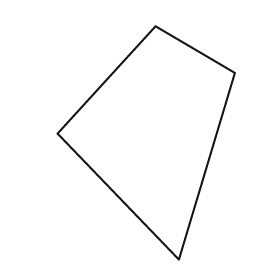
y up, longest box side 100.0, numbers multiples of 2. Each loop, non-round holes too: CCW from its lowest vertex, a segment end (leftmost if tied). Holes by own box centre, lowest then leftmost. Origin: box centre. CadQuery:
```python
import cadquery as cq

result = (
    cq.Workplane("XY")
    .moveTo(14.0, -50.0)
    .lineTo(38.0, 30.0)
    .lineTo(4.0, 50.0)
    .lineTo(-38.0, 4.0)
    .close()
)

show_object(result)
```